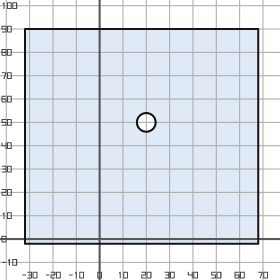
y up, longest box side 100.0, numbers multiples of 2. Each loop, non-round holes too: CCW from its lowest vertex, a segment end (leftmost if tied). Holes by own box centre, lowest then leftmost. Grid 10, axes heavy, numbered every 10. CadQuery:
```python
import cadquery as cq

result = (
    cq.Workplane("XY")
    .moveTo(-32.0, -2.0)
    .lineTo(68.0, -2.0)
    .lineTo(68.0, 90.0)
    .lineTo(-32.0, 90.0)
    .close()
    .moveTo(20.0, 50.0)
    .circle(4.0)
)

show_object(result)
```